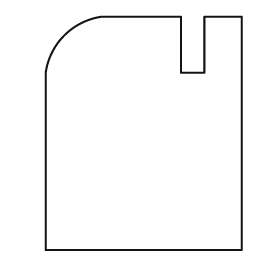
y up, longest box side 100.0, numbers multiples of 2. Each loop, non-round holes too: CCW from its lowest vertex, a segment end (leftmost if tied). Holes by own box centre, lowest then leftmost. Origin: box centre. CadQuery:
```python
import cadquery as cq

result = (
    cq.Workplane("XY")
    .moveTo(-42.0, -50.0)
    .lineTo(42.0, -50.0)
    .lineTo(42.0, 50.0)
    .lineTo(26.0, 50.0)
    .lineTo(26.0, 26.0)
    .lineTo(16.0, 26.0)
    .lineTo(16.0, 50.0)
    .lineTo(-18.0, 50.0)
    .threePointArc((-34.0, 42.0), (-42.0, 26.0))
    .close()
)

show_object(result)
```